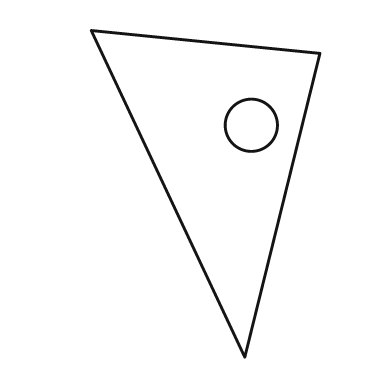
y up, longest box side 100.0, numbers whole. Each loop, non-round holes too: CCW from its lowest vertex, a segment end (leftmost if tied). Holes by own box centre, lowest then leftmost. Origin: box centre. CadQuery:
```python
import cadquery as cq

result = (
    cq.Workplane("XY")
    .moveTo(12.0, -50.0)
    .lineTo(35.0, 43.0)
    .lineTo(-35.0, 50.0)
    .close()
    .moveTo(14.0, 21.0)
    .circle(8.0)
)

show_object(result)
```